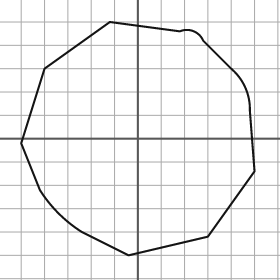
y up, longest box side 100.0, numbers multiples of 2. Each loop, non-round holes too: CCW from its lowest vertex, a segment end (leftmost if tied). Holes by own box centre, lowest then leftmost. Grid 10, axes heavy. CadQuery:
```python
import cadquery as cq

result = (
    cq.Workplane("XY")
    .moveTo(-4.0, -50.0)
    .lineTo(30.0, -42.0)
    .lineTo(50.0, -14.0)
    .lineTo(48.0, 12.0)
    .threePointArc((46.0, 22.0), (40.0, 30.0))
    .lineTo(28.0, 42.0)
    .threePointArc((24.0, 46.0), (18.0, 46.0))
    .lineTo(-12.0, 50.0)
    .lineTo(-40.0, 30.0)
    .lineTo(-50.0, -2.0)
    .lineTo(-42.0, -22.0)
    .threePointArc((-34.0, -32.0), (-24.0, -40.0))
    .close()
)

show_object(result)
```